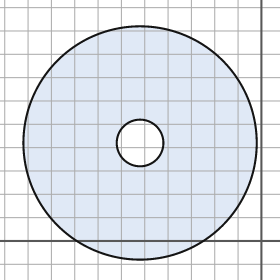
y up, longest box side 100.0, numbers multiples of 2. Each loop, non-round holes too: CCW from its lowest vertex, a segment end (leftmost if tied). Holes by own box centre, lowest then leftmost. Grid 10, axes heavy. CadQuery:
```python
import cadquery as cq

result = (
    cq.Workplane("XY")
    .moveTo(-52.0, 42.0)
    .circle(50.0)
    .moveTo(-52.0, 42.0)
    .circle(10.0)
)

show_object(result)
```